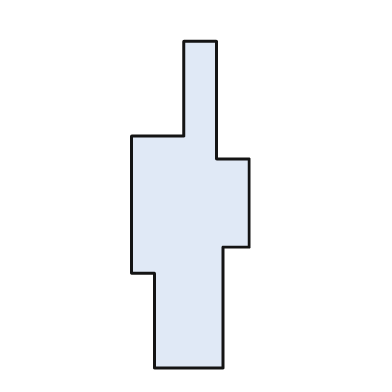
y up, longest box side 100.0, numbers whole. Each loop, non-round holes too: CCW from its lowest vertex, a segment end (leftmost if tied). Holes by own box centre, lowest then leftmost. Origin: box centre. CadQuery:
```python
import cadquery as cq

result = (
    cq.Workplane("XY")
    .moveTo(-11.0, -50.0)
    .lineTo(10.0, -50.0)
    .lineTo(10.0, -13.0)
    .lineTo(18.0, -13.0)
    .lineTo(18.0, 14.0)
    .lineTo(8.0, 14.0)
    .lineTo(8.0, 50.0)
    .lineTo(-2.0, 50.0)
    .lineTo(-2.0, 21.0)
    .lineTo(-18.0, 21.0)
    .lineTo(-18.0, -21.0)
    .lineTo(-11.0, -21.0)
    .close()
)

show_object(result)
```